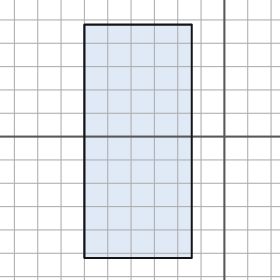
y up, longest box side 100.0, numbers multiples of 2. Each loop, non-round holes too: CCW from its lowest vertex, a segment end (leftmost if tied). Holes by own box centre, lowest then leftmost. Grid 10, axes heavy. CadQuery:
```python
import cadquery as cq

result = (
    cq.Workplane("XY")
    .moveTo(-60.0, -52.0)
    .lineTo(-14.0, -52.0)
    .lineTo(-14.0, 48.0)
    .lineTo(-60.0, 48.0)
    .close()
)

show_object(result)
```